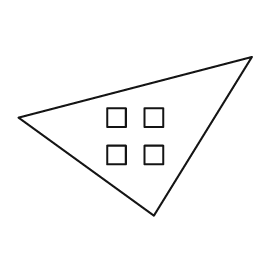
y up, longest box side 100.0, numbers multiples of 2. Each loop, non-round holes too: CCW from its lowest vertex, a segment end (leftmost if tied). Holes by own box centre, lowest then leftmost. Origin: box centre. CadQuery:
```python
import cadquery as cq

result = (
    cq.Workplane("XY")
    .moveTo(8.0, -34.0)
    .lineTo(50.0, 34.0)
    .lineTo(-50.0, 8.0)
    .close()
    .moveTo(-12.0, -12.0)
    .lineTo(-4.0, -12.0)
    .lineTo(-4.0, -4.0)
    .lineTo(-12.0, -4.0)
    .close()
    .moveTo(4.0, -12.0)
    .lineTo(12.0, -12.0)
    .lineTo(12.0, -4.0)
    .lineTo(4.0, -4.0)
    .close()
    .moveTo(-12.0, 4.0)
    .lineTo(-4.0, 4.0)
    .lineTo(-4.0, 12.0)
    .lineTo(-12.0, 12.0)
    .close()
    .moveTo(4.0, 4.0)
    .lineTo(12.0, 4.0)
    .lineTo(12.0, 12.0)
    .lineTo(4.0, 12.0)
    .close()
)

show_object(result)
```